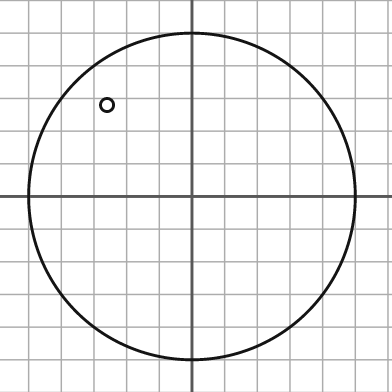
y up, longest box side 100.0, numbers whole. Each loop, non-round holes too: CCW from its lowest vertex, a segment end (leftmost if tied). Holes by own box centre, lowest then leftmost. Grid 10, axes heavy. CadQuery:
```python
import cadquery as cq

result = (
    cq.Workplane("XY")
    .moveTo(0.0, 0.0)
    .circle(50.0)
    .moveTo(-26.0, 28.0)
    .circle(2.0)
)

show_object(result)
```